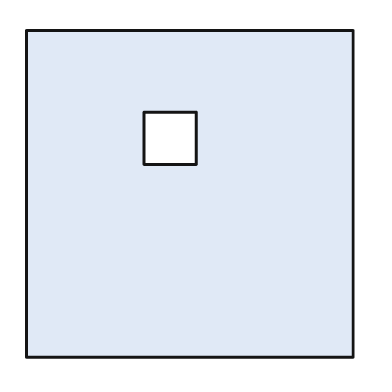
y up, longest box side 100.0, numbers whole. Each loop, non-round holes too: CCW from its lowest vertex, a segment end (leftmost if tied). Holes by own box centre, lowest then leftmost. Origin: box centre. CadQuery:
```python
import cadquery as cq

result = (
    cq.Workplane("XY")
    .moveTo(-50.0, -50.0)
    .lineTo(50.0, -50.0)
    .lineTo(50.0, 50.0)
    .lineTo(-50.0, 50.0)
    .close()
    .moveTo(-14.0, 9.0)
    .lineTo(2.0, 9.0)
    .lineTo(2.0, 25.0)
    .lineTo(-14.0, 25.0)
    .close()
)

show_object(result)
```